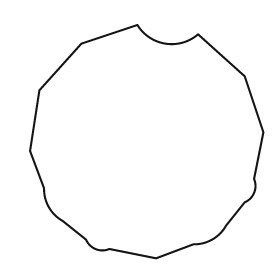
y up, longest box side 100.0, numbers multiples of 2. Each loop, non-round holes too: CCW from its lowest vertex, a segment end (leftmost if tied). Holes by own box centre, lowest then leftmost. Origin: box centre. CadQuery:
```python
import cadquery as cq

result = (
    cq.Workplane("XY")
    .moveTo(4.0, -50.0)
    .lineTo(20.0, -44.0)
    .threePointArc((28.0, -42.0), (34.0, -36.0))
    .lineTo(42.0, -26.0)
    .threePointArc((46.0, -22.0), (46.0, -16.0))
    .lineTo(50.0, 4.0)
    .lineTo(42.0, 28.0)
    .lineTo(22.0, 46.0)
    .threePointArc((8.0, 42.0), (-4.0, 50.0))
    .lineTo(-28.0, 42.0)
    .lineTo(-46.0, 22.0)
    .lineTo(-50.0, -4.0)
    .lineTo(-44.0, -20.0)
    .threePointArc((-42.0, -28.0), (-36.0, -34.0))
    .lineTo(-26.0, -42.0)
    .threePointArc((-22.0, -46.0), (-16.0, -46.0))
    .close()
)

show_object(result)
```